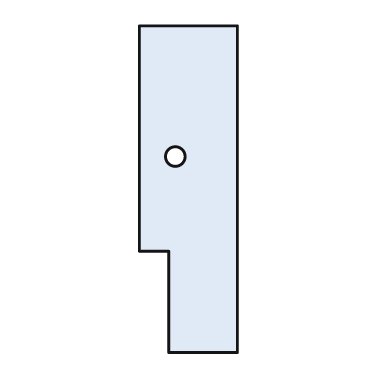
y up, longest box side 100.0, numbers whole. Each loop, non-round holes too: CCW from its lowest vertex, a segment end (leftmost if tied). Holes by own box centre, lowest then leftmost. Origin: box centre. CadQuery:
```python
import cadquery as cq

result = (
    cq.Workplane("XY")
    .moveTo(-6.0, -50.0)
    .lineTo(15.0, -50.0)
    .lineTo(15.0, 50.0)
    .lineTo(-15.0, 50.0)
    .lineTo(-15.0, -19.0)
    .lineTo(-6.0, -19.0)
    .close()
    .moveTo(-4.0, 10.0)
    .circle(3.0)
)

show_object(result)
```